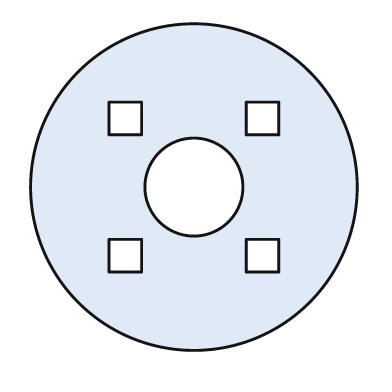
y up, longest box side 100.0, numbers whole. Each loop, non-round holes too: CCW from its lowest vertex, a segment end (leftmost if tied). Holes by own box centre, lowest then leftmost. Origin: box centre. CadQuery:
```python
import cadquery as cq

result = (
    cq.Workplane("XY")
    .moveTo(0.0, 0.0)
    .circle(50.0)
    .moveTo(-26.0, -26.0)
    .lineTo(-16.0, -26.0)
    .lineTo(-16.0, -16.0)
    .lineTo(-26.0, -16.0)
    .close()
    .moveTo(16.0, -26.0)
    .lineTo(26.0, -26.0)
    .lineTo(26.0, -16.0)
    .lineTo(16.0, -16.0)
    .close()
    .moveTo(0.0, 0.0)
    .circle(15.0)
    .moveTo(-26.0, 16.0)
    .lineTo(-16.0, 16.0)
    .lineTo(-16.0, 26.0)
    .lineTo(-26.0, 26.0)
    .close()
    .moveTo(16.0, 16.0)
    .lineTo(26.0, 16.0)
    .lineTo(26.0, 26.0)
    .lineTo(16.0, 26.0)
    .close()
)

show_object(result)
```